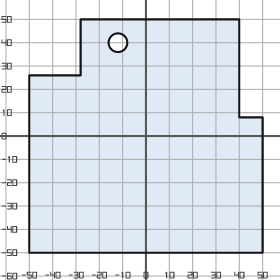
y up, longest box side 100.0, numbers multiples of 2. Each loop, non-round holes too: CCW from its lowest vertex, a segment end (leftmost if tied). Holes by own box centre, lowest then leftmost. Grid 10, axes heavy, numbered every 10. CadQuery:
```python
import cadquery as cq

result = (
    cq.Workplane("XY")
    .moveTo(-50.0, -50.0)
    .lineTo(50.0, -50.0)
    .lineTo(50.0, 8.0)
    .lineTo(40.0, 8.0)
    .lineTo(40.0, 50.0)
    .lineTo(-28.0, 50.0)
    .lineTo(-28.0, 26.0)
    .lineTo(-50.0, 26.0)
    .close()
    .moveTo(-12.0, 40.0)
    .circle(4.0)
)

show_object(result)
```